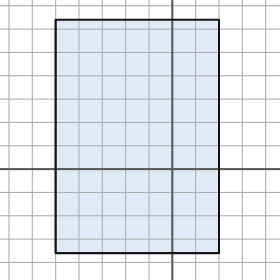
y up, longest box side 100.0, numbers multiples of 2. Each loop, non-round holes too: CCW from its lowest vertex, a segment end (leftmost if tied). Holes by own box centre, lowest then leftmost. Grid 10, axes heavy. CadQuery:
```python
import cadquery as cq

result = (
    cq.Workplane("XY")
    .moveTo(-50.0, -36.0)
    .lineTo(20.0, -36.0)
    .lineTo(20.0, 64.0)
    .lineTo(-50.0, 64.0)
    .close()
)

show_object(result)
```